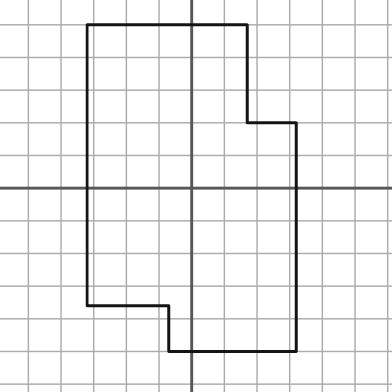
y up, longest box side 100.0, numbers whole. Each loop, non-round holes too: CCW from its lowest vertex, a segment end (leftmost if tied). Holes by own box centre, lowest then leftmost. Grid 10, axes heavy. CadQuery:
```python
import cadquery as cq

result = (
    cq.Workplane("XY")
    .moveTo(-7.0, -50.0)
    .lineTo(32.0, -50.0)
    .lineTo(32.0, 20.0)
    .lineTo(17.0, 20.0)
    .lineTo(17.0, 50.0)
    .lineTo(-32.0, 50.0)
    .lineTo(-32.0, -36.0)
    .lineTo(-7.0, -36.0)
    .close()
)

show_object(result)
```